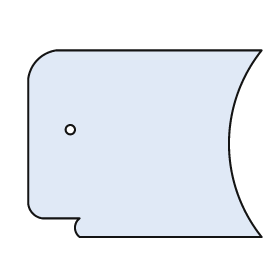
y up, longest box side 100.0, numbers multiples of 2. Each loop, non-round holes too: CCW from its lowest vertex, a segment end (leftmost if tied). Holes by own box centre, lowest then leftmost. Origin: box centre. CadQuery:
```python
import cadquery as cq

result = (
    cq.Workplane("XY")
    .moveTo(-28.0, -40.0)
    .lineTo(50.0, -40.0)
    .threePointArc((36.0, 0.0), (50.0, 40.0))
    .lineTo(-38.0, 40.0)
    .threePointArc((-46.0, 36.0), (-50.0, 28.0))
    .lineTo(-50.0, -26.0)
    .threePointArc((-48.0, -30.0), (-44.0, -32.0))
    .lineTo(-28.0, -32.0)
    .threePointArc((-30.0, -36.0), (-28.0, -40.0))
    .close()
    .moveTo(-32.0, 6.0)
    .circle(2.0)
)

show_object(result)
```